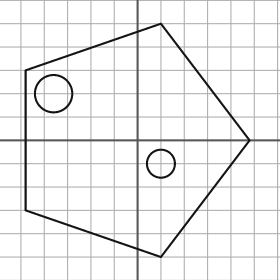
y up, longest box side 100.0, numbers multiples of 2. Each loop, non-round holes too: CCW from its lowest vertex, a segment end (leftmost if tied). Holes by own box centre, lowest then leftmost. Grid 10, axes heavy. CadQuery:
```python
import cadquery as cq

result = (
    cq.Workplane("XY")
    .moveTo(10.0, -50.0)
    .lineTo(48.0, 0.0)
    .lineTo(10.0, 50.0)
    .lineTo(-48.0, 30.0)
    .lineTo(-48.0, -30.0)
    .close()
    .moveTo(10.0, -10.0)
    .circle(6.0)
    .moveTo(-36.0, 20.0)
    .circle(8.0)
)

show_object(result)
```